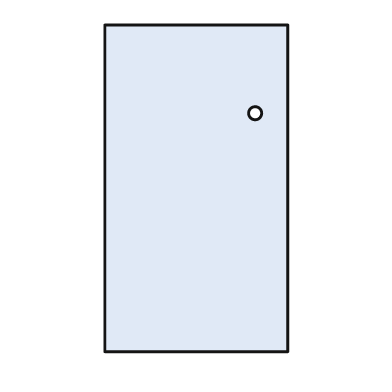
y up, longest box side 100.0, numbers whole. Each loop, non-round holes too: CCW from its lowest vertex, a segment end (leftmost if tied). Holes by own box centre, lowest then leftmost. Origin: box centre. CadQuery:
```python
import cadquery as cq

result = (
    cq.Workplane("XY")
    .moveTo(-28.0, -50.0)
    .lineTo(28.0, -50.0)
    .lineTo(28.0, 50.0)
    .lineTo(-28.0, 50.0)
    .close()
    .moveTo(18.0, 23.0)
    .circle(2.0)
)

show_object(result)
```